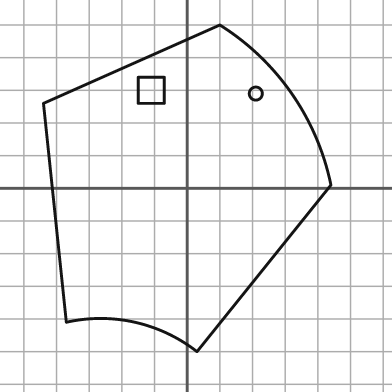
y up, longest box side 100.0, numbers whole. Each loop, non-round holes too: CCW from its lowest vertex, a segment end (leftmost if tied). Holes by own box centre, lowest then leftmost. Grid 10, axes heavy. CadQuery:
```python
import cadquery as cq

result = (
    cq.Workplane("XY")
    .moveTo(3.0, -50.0)
    .lineTo(44.0, 1.0)
    .threePointArc((32.0, 29.0), (10.0, 50.0))
    .lineTo(-44.0, 26.0)
    .lineTo(-37.0, -41.0)
    .threePointArc((-16.0, -41.0), (3.0, -50.0))
    .close()
    .moveTo(21.0, 29.0)
    .circle(2.0)
    .moveTo(-15.0, 26.0)
    .lineTo(-7.0, 26.0)
    .lineTo(-7.0, 34.0)
    .lineTo(-15.0, 34.0)
    .close()
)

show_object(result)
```